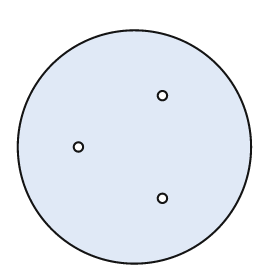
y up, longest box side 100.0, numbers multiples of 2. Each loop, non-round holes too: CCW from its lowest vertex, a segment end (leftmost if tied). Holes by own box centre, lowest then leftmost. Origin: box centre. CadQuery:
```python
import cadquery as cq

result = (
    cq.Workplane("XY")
    .moveTo(0.0, 0.0)
    .circle(50.0)
    .moveTo(12.0, -22.0)
    .circle(2.0)
    .moveTo(-24.0, 0.0)
    .circle(2.0)
    .moveTo(12.0, 22.0)
    .circle(2.0)
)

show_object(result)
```